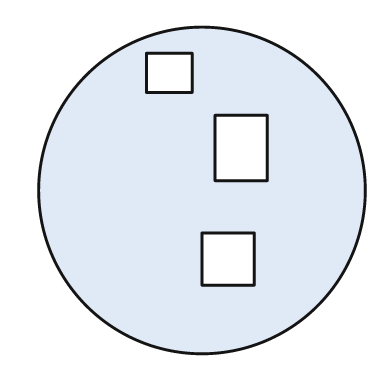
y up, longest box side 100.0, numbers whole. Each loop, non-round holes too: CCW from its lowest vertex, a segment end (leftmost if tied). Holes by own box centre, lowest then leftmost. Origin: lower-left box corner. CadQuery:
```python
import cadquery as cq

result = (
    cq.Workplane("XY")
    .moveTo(50.0, 50.0)
    .circle(50.0)
    .moveTo(50.0, 21.0)
    .lineTo(66.0, 21.0)
    .lineTo(66.0, 37.0)
    .lineTo(50.0, 37.0)
    .close()
    .moveTo(54.0, 53.0)
    .lineTo(70.0, 53.0)
    .lineTo(70.0, 73.0)
    .lineTo(54.0, 73.0)
    .close()
    .moveTo(33.0, 80.0)
    .lineTo(47.0, 80.0)
    .lineTo(47.0, 92.0)
    .lineTo(33.0, 92.0)
    .close()
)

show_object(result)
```